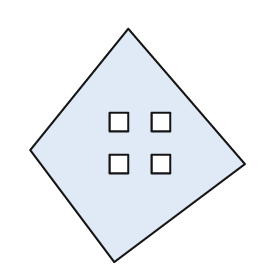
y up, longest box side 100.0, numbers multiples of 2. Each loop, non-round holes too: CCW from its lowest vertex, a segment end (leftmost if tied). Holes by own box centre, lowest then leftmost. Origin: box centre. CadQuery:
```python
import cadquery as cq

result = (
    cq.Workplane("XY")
    .moveTo(-10.0, -50.0)
    .lineTo(46.0, -8.0)
    .lineTo(-4.0, 50.0)
    .lineTo(-46.0, -2.0)
    .close()
    .moveTo(-12.0, -12.0)
    .lineTo(-4.0, -12.0)
    .lineTo(-4.0, -4.0)
    .lineTo(-12.0, -4.0)
    .close()
    .moveTo(6.0, -12.0)
    .lineTo(14.0, -12.0)
    .lineTo(14.0, -4.0)
    .lineTo(6.0, -4.0)
    .close()
    .moveTo(-12.0, 6.0)
    .lineTo(-4.0, 6.0)
    .lineTo(-4.0, 14.0)
    .lineTo(-12.0, 14.0)
    .close()
    .moveTo(6.0, 6.0)
    .lineTo(14.0, 6.0)
    .lineTo(14.0, 14.0)
    .lineTo(6.0, 14.0)
    .close()
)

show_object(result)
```